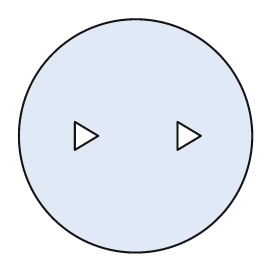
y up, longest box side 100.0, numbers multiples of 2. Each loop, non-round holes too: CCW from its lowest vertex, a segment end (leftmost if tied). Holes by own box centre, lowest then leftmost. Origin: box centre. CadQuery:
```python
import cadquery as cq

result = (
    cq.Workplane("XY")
    .moveTo(0.0, 0.0)
    .circle(50.0)
    .moveTo(-26.0, -6.0)
    .lineTo(-16.0, 0.0)
    .lineTo(-26.0, 6.0)
    .close()
    .moveTo(18.0, -6.0)
    .lineTo(28.0, 0.0)
    .lineTo(18.0, 6.0)
    .close()
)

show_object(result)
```